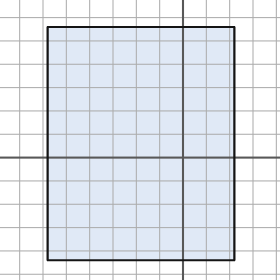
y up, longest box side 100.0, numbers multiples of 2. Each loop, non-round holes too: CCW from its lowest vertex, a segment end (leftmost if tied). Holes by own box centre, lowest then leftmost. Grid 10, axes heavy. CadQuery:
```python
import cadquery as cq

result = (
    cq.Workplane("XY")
    .moveTo(-58.0, -44.0)
    .lineTo(22.0, -44.0)
    .lineTo(22.0, 56.0)
    .lineTo(-58.0, 56.0)
    .close()
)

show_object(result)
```